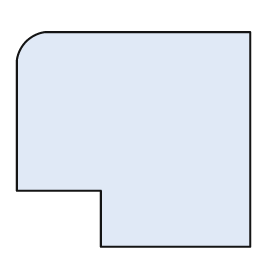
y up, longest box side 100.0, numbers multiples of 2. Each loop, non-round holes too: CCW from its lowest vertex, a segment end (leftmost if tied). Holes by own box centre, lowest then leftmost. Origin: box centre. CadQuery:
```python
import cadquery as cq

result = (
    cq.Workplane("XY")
    .moveTo(-14.0, -46.0)
    .lineTo(50.0, -46.0)
    .lineTo(50.0, 46.0)
    .lineTo(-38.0, 46.0)
    .threePointArc((-46.0, 42.0), (-50.0, 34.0))
    .lineTo(-50.0, -22.0)
    .lineTo(-14.0, -22.0)
    .close()
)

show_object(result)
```